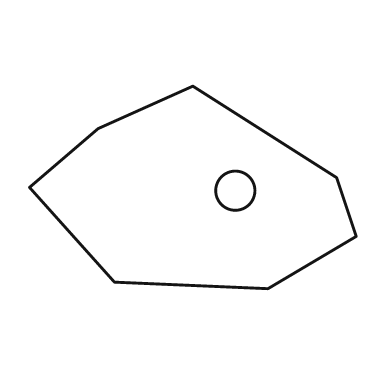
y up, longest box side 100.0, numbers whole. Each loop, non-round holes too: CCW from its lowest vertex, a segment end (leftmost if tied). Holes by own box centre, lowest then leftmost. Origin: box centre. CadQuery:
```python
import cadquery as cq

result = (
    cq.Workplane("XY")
    .moveTo(23.0, -31.0)
    .lineTo(50.0, -15.0)
    .lineTo(44.0, 3.0)
    .lineTo(0.0, 31.0)
    .lineTo(-29.0, 18.0)
    .lineTo(-50.0, 0.0)
    .lineTo(-24.0, -29.0)
    .close()
    .moveTo(13.0, -1.0)
    .circle(6.0)
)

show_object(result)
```